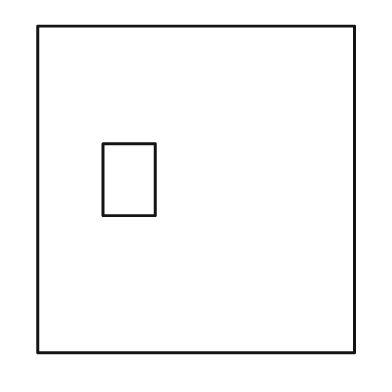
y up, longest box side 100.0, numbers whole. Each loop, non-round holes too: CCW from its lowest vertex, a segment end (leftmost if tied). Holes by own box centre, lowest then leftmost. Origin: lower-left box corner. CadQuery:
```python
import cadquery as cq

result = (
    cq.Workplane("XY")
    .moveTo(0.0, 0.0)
    .lineTo(97.0, 0.0)
    .lineTo(97.0, 100.0)
    .lineTo(0.0, 100.0)
    .close()
    .moveTo(20.0, 42.0)
    .lineTo(36.0, 42.0)
    .lineTo(36.0, 64.0)
    .lineTo(20.0, 64.0)
    .close()
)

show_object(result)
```